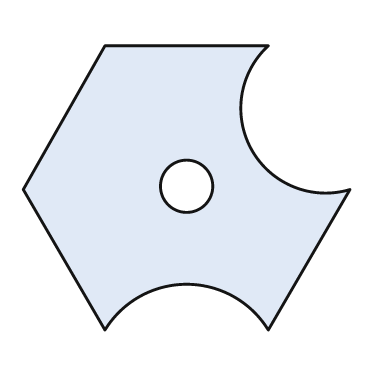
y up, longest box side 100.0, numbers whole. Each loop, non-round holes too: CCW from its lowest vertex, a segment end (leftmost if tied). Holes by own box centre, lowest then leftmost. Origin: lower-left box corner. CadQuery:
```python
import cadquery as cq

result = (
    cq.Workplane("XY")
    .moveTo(25.0, 0.0)
    .threePointArc((50.0, 14.0), (75.0, 0.0))
    .lineTo(100.0, 43.0)
    .threePointArc((70.0, 55.0), (75.0, 87.0))
    .lineTo(25.0, 87.0)
    .lineTo(0.0, 43.0)
    .close()
    .moveTo(50.0, 44.0)
    .circle(8.0)
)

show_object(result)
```